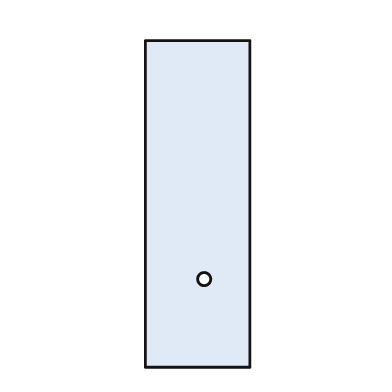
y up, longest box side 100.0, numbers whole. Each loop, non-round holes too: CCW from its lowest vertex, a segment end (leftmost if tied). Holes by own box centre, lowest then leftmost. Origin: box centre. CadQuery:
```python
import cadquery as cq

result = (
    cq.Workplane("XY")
    .moveTo(-16.0, -50.0)
    .lineTo(16.0, -50.0)
    .lineTo(16.0, 50.0)
    .lineTo(-16.0, 50.0)
    .close()
    .moveTo(2.0, -23.0)
    .circle(2.0)
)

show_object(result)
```